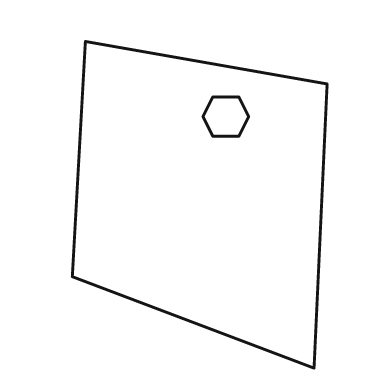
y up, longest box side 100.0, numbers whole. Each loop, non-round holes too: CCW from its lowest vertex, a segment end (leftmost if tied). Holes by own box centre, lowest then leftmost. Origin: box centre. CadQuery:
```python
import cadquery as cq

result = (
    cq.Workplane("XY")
    .moveTo(35.0, -50.0)
    .lineTo(39.0, 37.0)
    .lineTo(-35.0, 50.0)
    .lineTo(-39.0, -22.0)
    .close()
    .moveTo(4.0, 21.0)
    .lineTo(12.0, 21.0)
    .lineTo(15.0, 27.0)
    .lineTo(12.0, 33.0)
    .lineTo(4.0, 33.0)
    .lineTo(1.0, 27.0)
    .close()
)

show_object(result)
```